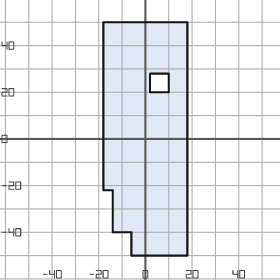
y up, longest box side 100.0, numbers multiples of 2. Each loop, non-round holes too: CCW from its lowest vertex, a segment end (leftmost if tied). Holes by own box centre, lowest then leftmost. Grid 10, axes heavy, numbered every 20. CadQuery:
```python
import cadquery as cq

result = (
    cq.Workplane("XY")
    .moveTo(-6.0, -50.0)
    .lineTo(18.0, -50.0)
    .lineTo(18.0, 50.0)
    .lineTo(-18.0, 50.0)
    .lineTo(-18.0, -22.0)
    .lineTo(-14.0, -22.0)
    .lineTo(-14.0, -40.0)
    .lineTo(-6.0, -40.0)
    .close()
    .moveTo(2.0, 20.0)
    .lineTo(10.0, 20.0)
    .lineTo(10.0, 28.0)
    .lineTo(2.0, 28.0)
    .close()
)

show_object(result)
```